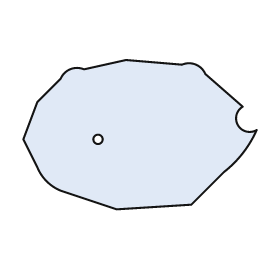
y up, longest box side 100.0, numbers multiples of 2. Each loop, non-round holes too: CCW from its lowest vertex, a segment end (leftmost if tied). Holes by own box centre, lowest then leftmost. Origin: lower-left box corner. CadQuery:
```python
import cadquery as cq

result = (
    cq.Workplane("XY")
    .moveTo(40.0, 0.0)
    .lineTo(72.0, 2.0)
    .lineTo(86.0, 16.0)
    .threePointArc((94.0, 24.0), (100.0, 34.0))
    .threePointArc((92.0, 36.0), (94.0, 44.0))
    .lineTo(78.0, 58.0)
    .threePointArc((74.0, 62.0), (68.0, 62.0))
    .lineTo(44.0, 64.0)
    .lineTo(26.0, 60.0)
    .threePointArc((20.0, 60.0), (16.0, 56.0))
    .lineTo(6.0, 46.0)
    .lineTo(0.0, 30.0)
    .lineTo(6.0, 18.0)
    .threePointArc((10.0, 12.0), (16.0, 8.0))
    .close()
    .moveTo(32.0, 30.0)
    .circle(2.0)
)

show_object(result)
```